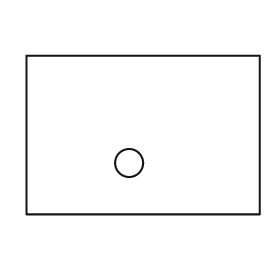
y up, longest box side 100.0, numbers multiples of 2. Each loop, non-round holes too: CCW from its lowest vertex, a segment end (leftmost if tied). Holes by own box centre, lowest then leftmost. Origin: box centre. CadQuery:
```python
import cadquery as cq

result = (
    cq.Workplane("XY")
    .moveTo(-50.0, -34.0)
    .lineTo(50.0, -34.0)
    .lineTo(50.0, 34.0)
    .lineTo(-50.0, 34.0)
    .close()
    .moveTo(-6.0, -12.0)
    .circle(6.0)
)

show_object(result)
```